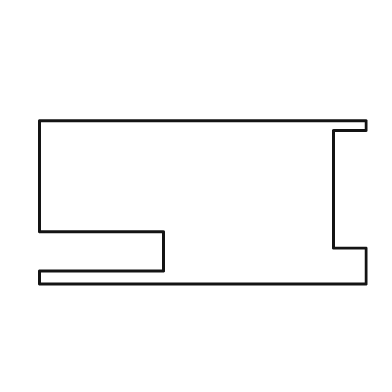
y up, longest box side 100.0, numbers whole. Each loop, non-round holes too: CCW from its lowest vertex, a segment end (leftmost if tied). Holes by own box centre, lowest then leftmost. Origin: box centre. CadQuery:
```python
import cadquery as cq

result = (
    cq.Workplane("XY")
    .moveTo(-50.0, -25.0)
    .lineTo(50.0, -25.0)
    .lineTo(50.0, -14.0)
    .lineTo(40.0, -14.0)
    .lineTo(40.0, 22.0)
    .lineTo(50.0, 22.0)
    .lineTo(50.0, 25.0)
    .lineTo(-50.0, 25.0)
    .lineTo(-50.0, -9.0)
    .lineTo(-12.0, -9.0)
    .lineTo(-12.0, -21.0)
    .lineTo(-50.0, -21.0)
    .close()
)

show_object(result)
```